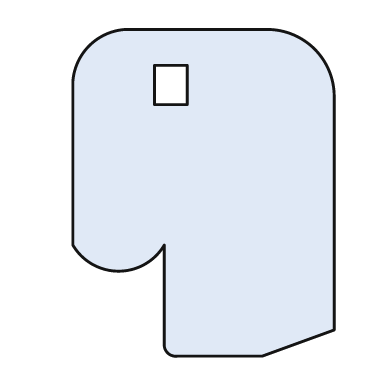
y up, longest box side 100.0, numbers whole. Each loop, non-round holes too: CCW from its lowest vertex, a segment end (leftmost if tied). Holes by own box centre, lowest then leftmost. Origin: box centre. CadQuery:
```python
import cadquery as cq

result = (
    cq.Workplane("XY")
    .moveTo(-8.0, -50.0)
    .lineTo(18.0, -50.0)
    .lineTo(40.0, -42.0)
    .lineTo(40.0, 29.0)
    .threePointArc((34.0, 44.0), (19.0, 50.0))
    .lineTo(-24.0, 50.0)
    .threePointArc((-35.0, 45.0), (-40.0, 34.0))
    .lineTo(-40.0, -16.0)
    .threePointArc((-26.0, -24.0), (-12.0, -16.0))
    .lineTo(-12.0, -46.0)
    .threePointArc((-11.0, -49.0), (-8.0, -50.0))
    .close()
    .moveTo(-15.0, 27.0)
    .lineTo(-5.0, 27.0)
    .lineTo(-5.0, 39.0)
    .lineTo(-15.0, 39.0)
    .close()
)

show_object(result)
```